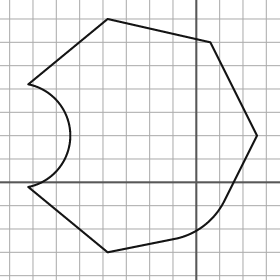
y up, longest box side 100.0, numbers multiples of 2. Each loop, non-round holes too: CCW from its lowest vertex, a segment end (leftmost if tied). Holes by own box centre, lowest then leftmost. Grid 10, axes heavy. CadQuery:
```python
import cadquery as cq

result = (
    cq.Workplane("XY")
    .moveTo(-38.0, -30.0)
    .lineTo(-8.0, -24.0)
    .threePointArc((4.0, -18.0), (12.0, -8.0))
    .lineTo(26.0, 20.0)
    .lineTo(6.0, 60.0)
    .lineTo(-38.0, 70.0)
    .lineTo(-72.0, 42.0)
    .threePointArc((-54.0, 20.0), (-72.0, -2.0))
    .close()
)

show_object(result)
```